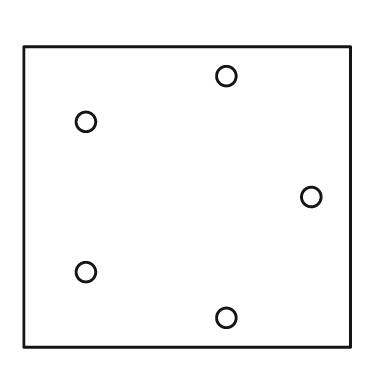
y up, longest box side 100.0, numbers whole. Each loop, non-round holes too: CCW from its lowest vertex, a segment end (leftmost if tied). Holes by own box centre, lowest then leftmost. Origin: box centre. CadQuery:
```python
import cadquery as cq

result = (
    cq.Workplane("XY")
    .moveTo(-50.0, -46.0)
    .lineTo(50.0, -46.0)
    .lineTo(50.0, 46.0)
    .lineTo(-50.0, 46.0)
    .close()
    .moveTo(12.0, -37.0)
    .circle(3.0)
    .moveTo(-31.0, -23.0)
    .circle(3.0)
    .moveTo(38.0, 0.0)
    .circle(3.0)
    .moveTo(-31.0, 23.0)
    .circle(3.0)
    .moveTo(12.0, 37.0)
    .circle(3.0)
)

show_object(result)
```